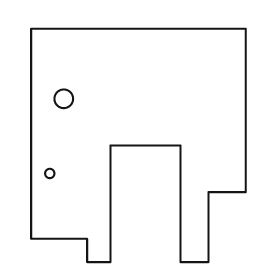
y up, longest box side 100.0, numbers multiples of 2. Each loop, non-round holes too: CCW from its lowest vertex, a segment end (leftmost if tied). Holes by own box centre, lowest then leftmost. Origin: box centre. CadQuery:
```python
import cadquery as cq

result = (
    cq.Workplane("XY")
    .moveTo(-22.0, -50.0)
    .lineTo(-12.0, -50.0)
    .lineTo(-12.0, 0.0)
    .lineTo(18.0, 0.0)
    .lineTo(18.0, -50.0)
    .lineTo(30.0, -50.0)
    .lineTo(30.0, -20.0)
    .lineTo(46.0, -20.0)
    .lineTo(46.0, 50.0)
    .lineTo(-46.0, 50.0)
    .lineTo(-46.0, -40.0)
    .lineTo(-22.0, -40.0)
    .close()
    .moveTo(-38.0, -12.0)
    .circle(2.0)
    .moveTo(-32.0, 20.0)
    .circle(4.0)
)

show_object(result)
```